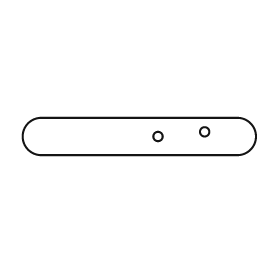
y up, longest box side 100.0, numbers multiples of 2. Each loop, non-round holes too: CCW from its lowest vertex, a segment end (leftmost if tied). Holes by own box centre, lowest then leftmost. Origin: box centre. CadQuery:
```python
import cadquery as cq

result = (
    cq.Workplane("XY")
    .moveTo(-42.0, -8.0)
    .lineTo(42.0, -8.0)
    .threePointArc((50.0, 0.0), (42.0, 8.0))
    .lineTo(-42.0, 8.0)
    .threePointArc((-50.0, 0.0), (-42.0, -8.0))
    .close()
    .moveTo(8.0, 0.0)
    .circle(2.0)
    .moveTo(28.0, 2.0)
    .circle(2.0)
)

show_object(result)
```